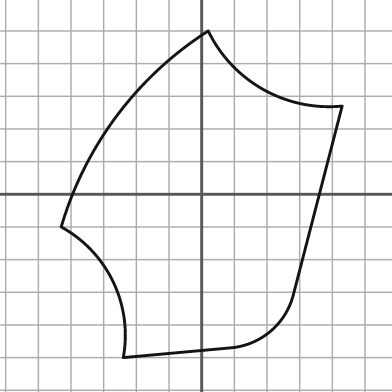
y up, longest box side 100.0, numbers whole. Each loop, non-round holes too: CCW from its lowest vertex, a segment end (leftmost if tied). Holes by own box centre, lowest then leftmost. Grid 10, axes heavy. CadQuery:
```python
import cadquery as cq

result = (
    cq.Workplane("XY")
    .moveTo(-24.0, -50.0)
    .lineTo(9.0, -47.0)
    .threePointArc((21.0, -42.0), (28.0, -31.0))
    .lineTo(43.0, 27.0)
    .threePointArc((19.0, 32.0), (2.0, 50.0))
    .threePointArc((-26.0, 24.0), (-43.0, -10.0))
    .threePointArc((-27.0, -27.0), (-24.0, -50.0))
    .close()
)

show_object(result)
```